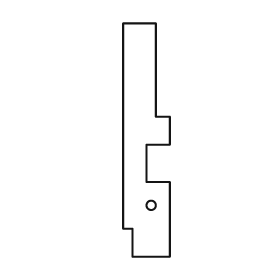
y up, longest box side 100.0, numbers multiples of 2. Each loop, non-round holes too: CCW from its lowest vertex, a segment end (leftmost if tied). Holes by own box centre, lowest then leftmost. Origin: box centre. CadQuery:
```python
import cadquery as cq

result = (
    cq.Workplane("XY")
    .moveTo(-6.0, -50.0)
    .lineTo(10.0, -50.0)
    .lineTo(10.0, -18.0)
    .lineTo(0.0, -18.0)
    .lineTo(0.0, -2.0)
    .lineTo(10.0, -2.0)
    .lineTo(10.0, 10.0)
    .lineTo(4.0, 10.0)
    .lineTo(4.0, 50.0)
    .lineTo(-10.0, 50.0)
    .lineTo(-10.0, -38.0)
    .lineTo(-6.0, -38.0)
    .close()
    .moveTo(2.0, -28.0)
    .circle(2.0)
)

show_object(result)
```